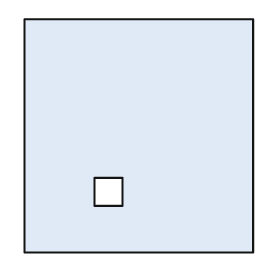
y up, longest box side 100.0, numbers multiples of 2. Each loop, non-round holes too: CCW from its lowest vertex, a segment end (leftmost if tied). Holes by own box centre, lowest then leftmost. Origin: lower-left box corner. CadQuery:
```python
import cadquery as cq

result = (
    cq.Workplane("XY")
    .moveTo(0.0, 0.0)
    .lineTo(98.0, 0.0)
    .lineTo(98.0, 100.0)
    .lineTo(0.0, 100.0)
    .close()
    .moveTo(30.0, 20.0)
    .lineTo(42.0, 20.0)
    .lineTo(42.0, 32.0)
    .lineTo(30.0, 32.0)
    .close()
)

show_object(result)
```